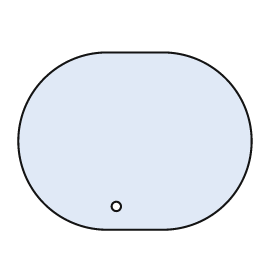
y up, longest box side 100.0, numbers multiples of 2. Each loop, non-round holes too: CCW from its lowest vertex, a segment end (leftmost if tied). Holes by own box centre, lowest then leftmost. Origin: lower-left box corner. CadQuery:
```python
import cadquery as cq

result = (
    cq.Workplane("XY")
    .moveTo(38.0, 0.0)
    .lineTo(62.0, 0.0)
    .threePointArc((100.0, 38.0), (62.0, 76.0))
    .lineTo(38.0, 76.0)
    .threePointArc((0.0, 38.0), (38.0, 0.0))
    .close()
    .moveTo(42.0, 10.0)
    .circle(2.0)
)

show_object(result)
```